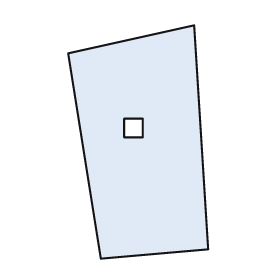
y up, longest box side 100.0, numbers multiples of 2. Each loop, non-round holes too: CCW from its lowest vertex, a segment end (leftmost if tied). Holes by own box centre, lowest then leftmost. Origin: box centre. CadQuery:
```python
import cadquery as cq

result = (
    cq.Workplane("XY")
    .moveTo(-16.0, -50.0)
    .lineTo(30.0, -46.0)
    .lineTo(24.0, 50.0)
    .lineTo(-30.0, 38.0)
    .close()
    .moveTo(-6.0, 2.0)
    .lineTo(2.0, 2.0)
    .lineTo(2.0, 10.0)
    .lineTo(-6.0, 10.0)
    .close()
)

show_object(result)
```